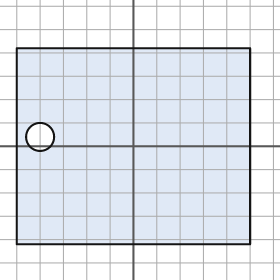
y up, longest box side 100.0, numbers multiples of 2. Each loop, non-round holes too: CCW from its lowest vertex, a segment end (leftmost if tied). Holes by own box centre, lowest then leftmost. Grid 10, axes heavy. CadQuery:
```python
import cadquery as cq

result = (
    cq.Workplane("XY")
    .moveTo(-50.0, -42.0)
    .lineTo(50.0, -42.0)
    .lineTo(50.0, 42.0)
    .lineTo(-50.0, 42.0)
    .close()
    .moveTo(-40.0, 4.0)
    .circle(6.0)
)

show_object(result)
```